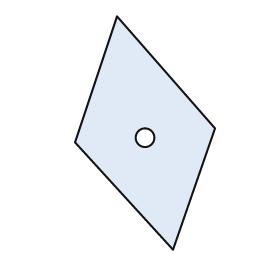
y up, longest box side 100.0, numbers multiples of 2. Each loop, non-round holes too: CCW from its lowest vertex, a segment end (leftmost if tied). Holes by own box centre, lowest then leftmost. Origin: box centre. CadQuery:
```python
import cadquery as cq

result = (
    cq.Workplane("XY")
    .moveTo(12.0, -50.0)
    .lineTo(30.0, 2.0)
    .lineTo(-12.0, 50.0)
    .lineTo(-30.0, -4.0)
    .close()
    .moveTo(0.0, -2.0)
    .circle(4.0)
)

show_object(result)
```